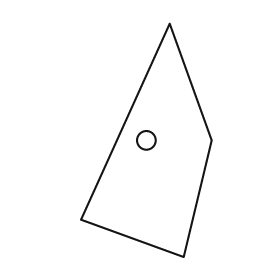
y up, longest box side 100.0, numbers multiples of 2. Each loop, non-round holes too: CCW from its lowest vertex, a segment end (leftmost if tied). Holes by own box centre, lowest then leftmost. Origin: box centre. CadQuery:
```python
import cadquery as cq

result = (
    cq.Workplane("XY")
    .moveTo(16.0, -50.0)
    .lineTo(28.0, 0.0)
    .lineTo(10.0, 50.0)
    .lineTo(-28.0, -34.0)
    .close()
    .moveTo(0.0, 0.0)
    .circle(4.0)
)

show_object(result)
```